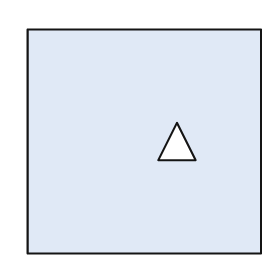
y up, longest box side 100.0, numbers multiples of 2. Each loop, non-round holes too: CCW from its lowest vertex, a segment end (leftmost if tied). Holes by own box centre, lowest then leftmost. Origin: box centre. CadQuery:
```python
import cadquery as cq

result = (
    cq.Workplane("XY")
    .moveTo(-50.0, -48.0)
    .lineTo(50.0, -48.0)
    .lineTo(50.0, 48.0)
    .lineTo(-50.0, 48.0)
    .close()
    .moveTo(6.0, -8.0)
    .lineTo(22.0, -8.0)
    .lineTo(14.0, 8.0)
    .close()
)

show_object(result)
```